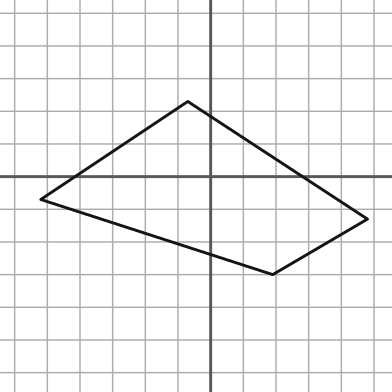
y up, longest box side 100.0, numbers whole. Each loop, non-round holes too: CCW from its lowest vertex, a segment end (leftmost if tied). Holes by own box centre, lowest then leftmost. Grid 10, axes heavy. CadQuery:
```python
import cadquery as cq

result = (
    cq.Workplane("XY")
    .moveTo(19.0, -30.0)
    .lineTo(48.0, -13.0)
    .lineTo(-7.0, 23.0)
    .lineTo(-52.0, -7.0)
    .close()
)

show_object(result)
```